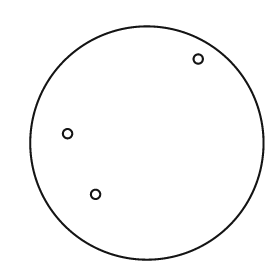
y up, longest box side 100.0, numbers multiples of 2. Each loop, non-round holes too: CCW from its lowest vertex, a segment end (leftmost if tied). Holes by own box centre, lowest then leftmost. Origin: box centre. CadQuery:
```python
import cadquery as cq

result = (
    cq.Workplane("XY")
    .moveTo(0.0, 0.0)
    .circle(50.0)
    .moveTo(-22.0, -22.0)
    .circle(2.0)
    .moveTo(-34.0, 4.0)
    .circle(2.0)
    .moveTo(22.0, 36.0)
    .circle(2.0)
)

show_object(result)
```